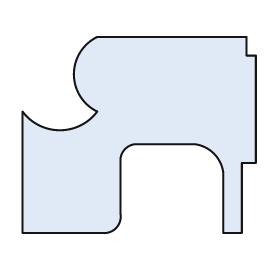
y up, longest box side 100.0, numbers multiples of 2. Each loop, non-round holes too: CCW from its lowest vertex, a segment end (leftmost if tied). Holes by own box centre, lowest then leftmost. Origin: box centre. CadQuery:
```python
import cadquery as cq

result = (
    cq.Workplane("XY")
    .moveTo(-50.0, -42.0)
    .lineTo(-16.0, -42.0)
    .threePointArc((-10.0, -40.0), (-8.0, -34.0))
    .lineTo(-8.0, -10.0)
    .threePointArc((-6.0, -6.0), (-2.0, -4.0))
    .lineTo(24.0, -4.0)
    .threePointArc((32.0, -8.0), (36.0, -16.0))
    .lineTo(36.0, -42.0)
    .lineTo(44.0, -42.0)
    .lineTo(44.0, -12.0)
    .lineTo(50.0, -12.0)
    .lineTo(50.0, 34.0)
    .lineTo(46.0, 34.0)
    .lineTo(46.0, 42.0)
    .lineTo(-18.0, 42.0)
    .threePointArc((-28.0, 26.0), (-18.0, 10.0))
    .threePointArc((-34.0, 2.0), (-50.0, 10.0))
    .close()
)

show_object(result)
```